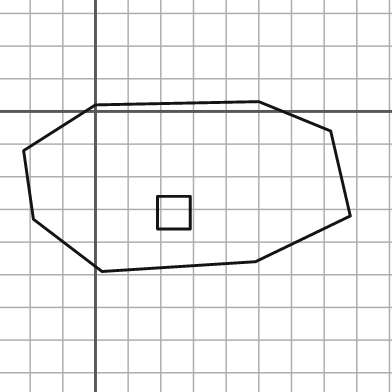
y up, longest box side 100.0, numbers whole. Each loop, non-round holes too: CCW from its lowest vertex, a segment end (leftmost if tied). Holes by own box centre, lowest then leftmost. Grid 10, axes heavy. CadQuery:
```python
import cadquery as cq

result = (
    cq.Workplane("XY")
    .moveTo(2.0, -49.0)
    .lineTo(49.0, -46.0)
    .lineTo(78.0, -32.0)
    .lineTo(72.0, -6.0)
    .lineTo(50.0, 3.0)
    .lineTo(0.0, 2.0)
    .lineTo(-22.0, -12.0)
    .lineTo(-19.0, -33.0)
    .close()
    .moveTo(19.0, -36.0)
    .lineTo(29.0, -36.0)
    .lineTo(29.0, -26.0)
    .lineTo(19.0, -26.0)
    .close()
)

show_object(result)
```